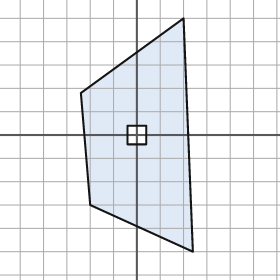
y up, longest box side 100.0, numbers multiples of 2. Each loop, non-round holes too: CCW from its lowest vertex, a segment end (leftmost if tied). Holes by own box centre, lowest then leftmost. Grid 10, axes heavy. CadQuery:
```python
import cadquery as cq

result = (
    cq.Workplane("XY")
    .moveTo(24.0, -50.0)
    .lineTo(20.0, 50.0)
    .lineTo(-24.0, 18.0)
    .lineTo(-20.0, -30.0)
    .close()
    .moveTo(-4.0, -4.0)
    .lineTo(4.0, -4.0)
    .lineTo(4.0, 4.0)
    .lineTo(-4.0, 4.0)
    .close()
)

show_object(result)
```